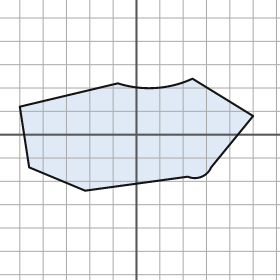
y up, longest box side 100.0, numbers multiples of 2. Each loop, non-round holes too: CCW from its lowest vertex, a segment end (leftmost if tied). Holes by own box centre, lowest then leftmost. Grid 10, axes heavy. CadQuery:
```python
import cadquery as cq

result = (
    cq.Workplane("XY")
    .moveTo(-22.0, -24.0)
    .lineTo(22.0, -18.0)
    .threePointArc((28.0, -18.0), (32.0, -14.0))
    .lineTo(50.0, 8.0)
    .lineTo(24.0, 24.0)
    .threePointArc((8.0, 20.0), (-8.0, 22.0))
    .lineTo(-50.0, 12.0)
    .lineTo(-46.0, -14.0)
    .close()
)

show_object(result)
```